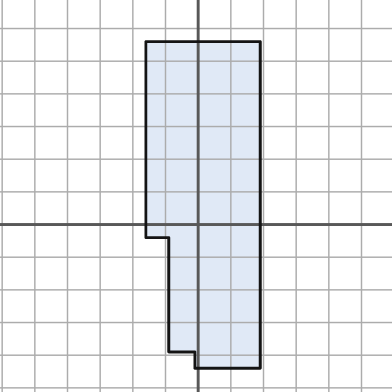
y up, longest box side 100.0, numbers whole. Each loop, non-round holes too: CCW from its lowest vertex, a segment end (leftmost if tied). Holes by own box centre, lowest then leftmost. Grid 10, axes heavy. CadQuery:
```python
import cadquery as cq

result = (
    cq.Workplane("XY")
    .moveTo(-1.0, -44.0)
    .lineTo(19.0, -44.0)
    .lineTo(19.0, 56.0)
    .lineTo(-16.0, 56.0)
    .lineTo(-16.0, -4.0)
    .lineTo(-9.0, -4.0)
    .lineTo(-9.0, -39.0)
    .lineTo(-1.0, -39.0)
    .close()
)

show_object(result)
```